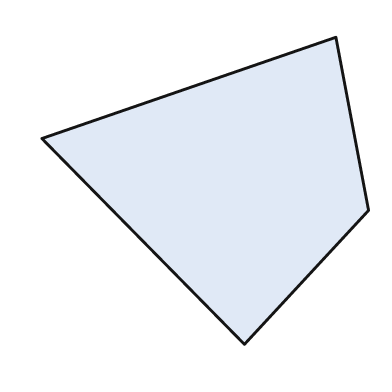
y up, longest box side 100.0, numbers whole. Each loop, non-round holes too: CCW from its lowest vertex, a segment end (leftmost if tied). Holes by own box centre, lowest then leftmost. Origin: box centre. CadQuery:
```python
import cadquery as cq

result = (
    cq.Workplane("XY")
    .moveTo(12.0, -47.0)
    .lineTo(50.0, -6.0)
    .lineTo(40.0, 47.0)
    .lineTo(-50.0, 16.0)
    .close()
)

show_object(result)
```